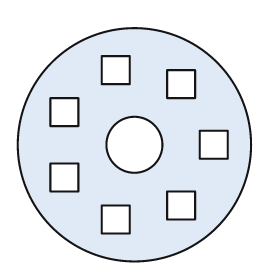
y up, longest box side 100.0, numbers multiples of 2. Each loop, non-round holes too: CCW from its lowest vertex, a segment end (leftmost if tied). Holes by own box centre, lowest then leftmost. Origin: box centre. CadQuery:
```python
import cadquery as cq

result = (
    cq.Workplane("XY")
    .moveTo(0.0, 0.0)
    .circle(50.0)
    .moveTo(-14.0, -38.0)
    .lineTo(-2.0, -38.0)
    .lineTo(-2.0, -26.0)
    .lineTo(-14.0, -26.0)
    .close()
    .moveTo(14.0, -32.0)
    .lineTo(26.0, -32.0)
    .lineTo(26.0, -20.0)
    .lineTo(14.0, -20.0)
    .close()
    .moveTo(-36.0, -20.0)
    .lineTo(-24.0, -20.0)
    .lineTo(-24.0, -8.0)
    .lineTo(-36.0, -8.0)
    .close()
    .moveTo(0.0, 0.0)
    .circle(12.0)
    .moveTo(28.0, -6.0)
    .lineTo(40.0, -6.0)
    .lineTo(40.0, 6.0)
    .lineTo(28.0, 6.0)
    .close()
    .moveTo(-36.0, 8.0)
    .lineTo(-24.0, 8.0)
    .lineTo(-24.0, 20.0)
    .lineTo(-36.0, 20.0)
    .close()
    .moveTo(14.0, 20.0)
    .lineTo(26.0, 20.0)
    .lineTo(26.0, 32.0)
    .lineTo(14.0, 32.0)
    .close()
    .moveTo(-14.0, 26.0)
    .lineTo(-2.0, 26.0)
    .lineTo(-2.0, 38.0)
    .lineTo(-14.0, 38.0)
    .close()
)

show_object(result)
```